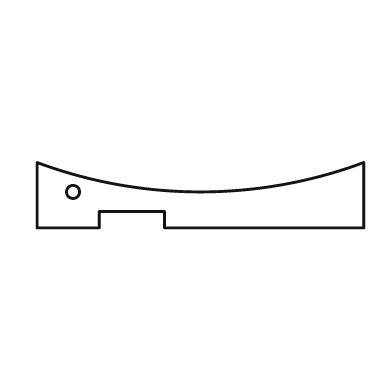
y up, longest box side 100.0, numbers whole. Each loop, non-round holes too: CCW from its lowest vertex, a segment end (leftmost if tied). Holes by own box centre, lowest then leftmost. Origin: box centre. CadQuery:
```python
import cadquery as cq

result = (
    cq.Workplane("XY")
    .moveTo(-50.0, -10.0)
    .lineTo(-31.0, -10.0)
    .lineTo(-31.0, -5.0)
    .lineTo(-11.0, -5.0)
    .lineTo(-11.0, -10.0)
    .lineTo(50.0, -10.0)
    .lineTo(50.0, 10.0)
    .threePointArc((0.0, 1.0), (-50.0, 10.0))
    .close()
    .moveTo(-39.0, 1.0)
    .circle(2.0)
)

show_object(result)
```